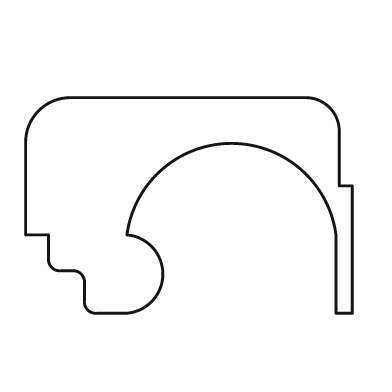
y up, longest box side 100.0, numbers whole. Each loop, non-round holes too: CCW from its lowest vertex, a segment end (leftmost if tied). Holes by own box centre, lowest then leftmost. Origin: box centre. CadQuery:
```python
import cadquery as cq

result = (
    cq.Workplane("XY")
    .moveTo(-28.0, -33.0)
    .lineTo(-19.0, -33.0)
    .threePointArc((-8.0, -21.0), (-19.0, -9.0))
    .threePointArc((13.0, 19.0), (45.0, -9.0))
    .lineTo(45.0, -33.0)
    .lineTo(50.0, -33.0)
    .lineTo(50.0, 6.0)
    .lineTo(46.0, 6.0)
    .lineTo(46.0, 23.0)
    .threePointArc((43.0, 30.0), (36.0, 33.0))
    .lineTo(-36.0, 33.0)
    .threePointArc((-46.0, 29.0), (-50.0, 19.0))
    .lineTo(-50.0, -9.0)
    .lineTo(-43.0, -9.0)
    .lineTo(-43.0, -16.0)
    .threePointArc((-42.0, -19.0), (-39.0, -20.0))
    .lineTo(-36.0, -20.0)
    .threePointArc((-33.0, -21.0), (-32.0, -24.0))
    .lineTo(-32.0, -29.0)
    .threePointArc((-31.0, -32.0), (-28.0, -33.0))
    .close()
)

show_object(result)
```